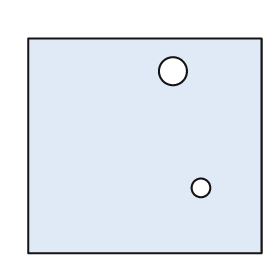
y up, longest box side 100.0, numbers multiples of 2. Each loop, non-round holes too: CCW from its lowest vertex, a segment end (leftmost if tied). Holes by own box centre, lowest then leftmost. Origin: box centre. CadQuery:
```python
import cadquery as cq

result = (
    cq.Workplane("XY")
    .moveTo(-50.0, -46.0)
    .lineTo(50.0, -46.0)
    .lineTo(50.0, 46.0)
    .lineTo(-50.0, 46.0)
    .close()
    .moveTo(24.0, -18.0)
    .circle(4.0)
    .moveTo(12.0, 32.0)
    .circle(6.0)
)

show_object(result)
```